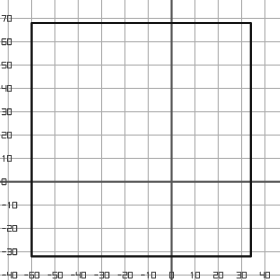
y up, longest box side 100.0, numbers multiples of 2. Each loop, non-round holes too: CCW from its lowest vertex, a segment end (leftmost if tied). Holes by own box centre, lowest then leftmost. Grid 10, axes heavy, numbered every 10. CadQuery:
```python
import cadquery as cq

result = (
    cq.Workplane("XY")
    .moveTo(-60.0, -32.0)
    .lineTo(34.0, -32.0)
    .lineTo(34.0, 68.0)
    .lineTo(-60.0, 68.0)
    .close()
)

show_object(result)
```